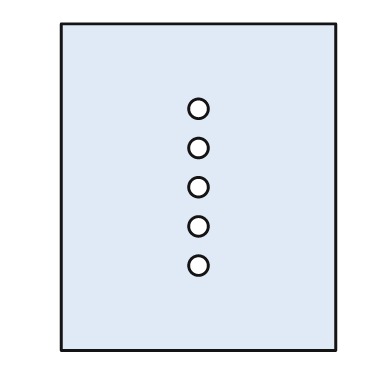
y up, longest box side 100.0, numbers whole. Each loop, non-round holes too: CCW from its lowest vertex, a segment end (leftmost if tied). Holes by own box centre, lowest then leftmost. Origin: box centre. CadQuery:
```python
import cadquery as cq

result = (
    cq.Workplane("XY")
    .moveTo(-42.0, -50.0)
    .lineTo(42.0, -50.0)
    .lineTo(42.0, 50.0)
    .lineTo(-42.0, 50.0)
    .close()
    .moveTo(0.0, -24.0)
    .circle(3.0)
    .moveTo(0.0, -12.0)
    .circle(3.0)
    .moveTo(0.0, 0.0)
    .circle(3.0)
    .moveTo(0.0, 12.0)
    .circle(3.0)
    .moveTo(0.0, 24.0)
    .circle(3.0)
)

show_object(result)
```